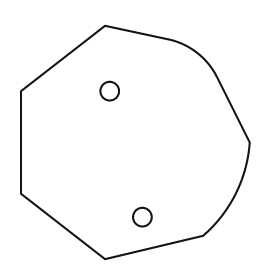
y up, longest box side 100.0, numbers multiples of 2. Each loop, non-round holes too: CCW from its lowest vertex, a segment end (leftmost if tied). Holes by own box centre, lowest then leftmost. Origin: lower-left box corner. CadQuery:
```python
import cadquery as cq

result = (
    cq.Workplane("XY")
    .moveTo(36.0, 0.0)
    .lineTo(78.0, 10.0)
    .threePointArc((92.0, 28.0), (98.0, 50.0))
    .lineTo(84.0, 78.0)
    .threePointArc((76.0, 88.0), (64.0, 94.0))
    .lineTo(36.0, 100.0)
    .lineTo(0.0, 72.0)
    .lineTo(0.0, 28.0)
    .close()
    .moveTo(52.0, 18.0)
    .circle(4.0)
    .moveTo(38.0, 72.0)
    .circle(4.0)
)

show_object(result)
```